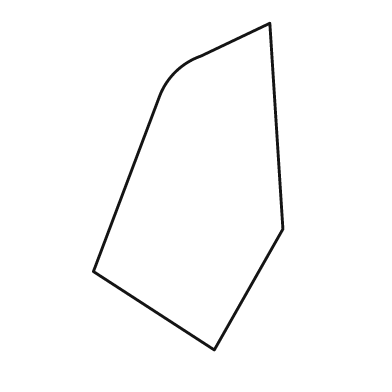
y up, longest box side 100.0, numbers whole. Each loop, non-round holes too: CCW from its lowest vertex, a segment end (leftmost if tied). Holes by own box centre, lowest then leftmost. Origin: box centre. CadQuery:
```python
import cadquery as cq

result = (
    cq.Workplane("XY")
    .moveTo(8.0, -50.0)
    .lineTo(29.0, -13.0)
    .lineTo(25.0, 50.0)
    .lineTo(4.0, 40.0)
    .threePointArc((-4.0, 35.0), (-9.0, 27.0))
    .lineTo(-29.0, -26.0)
    .close()
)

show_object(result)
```